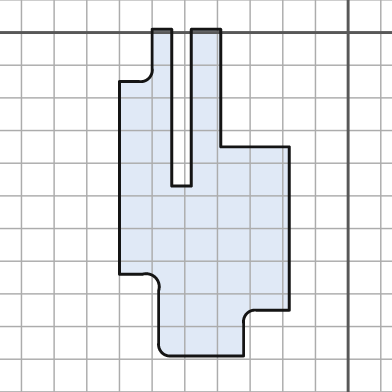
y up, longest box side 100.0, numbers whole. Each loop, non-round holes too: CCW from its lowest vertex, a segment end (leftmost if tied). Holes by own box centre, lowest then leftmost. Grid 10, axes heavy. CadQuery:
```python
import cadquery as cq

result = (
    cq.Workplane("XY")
    .moveTo(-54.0, -99.0)
    .lineTo(-32.0, -99.0)
    .lineTo(-32.0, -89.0)
    .threePointArc((-31.0, -86.0), (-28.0, -85.0))
    .lineTo(-18.0, -85.0)
    .lineTo(-18.0, -35.0)
    .lineTo(-39.0, -35.0)
    .lineTo(-39.0, 1.0)
    .lineTo(-48.0, 1.0)
    .lineTo(-48.0, -47.0)
    .lineTo(-54.0, -47.0)
    .lineTo(-54.0, 1.0)
    .lineTo(-60.0, 1.0)
    .lineTo(-60.0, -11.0)
    .threePointArc((-61.0, -14.0), (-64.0, -15.0))
    .lineTo(-70.0, -15.0)
    .lineTo(-70.0, -74.0)
    .lineTo(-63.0, -74.0)
    .threePointArc((-59.0, -75.0), (-58.0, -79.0))
    .lineTo(-58.0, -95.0)
    .threePointArc((-57.0, -98.0), (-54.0, -99.0))
    .close()
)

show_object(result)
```